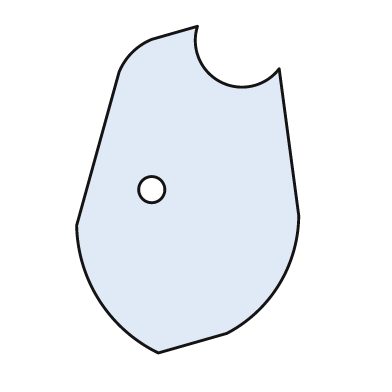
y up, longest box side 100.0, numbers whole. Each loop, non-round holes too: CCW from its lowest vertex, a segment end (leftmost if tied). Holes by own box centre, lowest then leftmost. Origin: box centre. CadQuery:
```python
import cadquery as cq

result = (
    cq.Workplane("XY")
    .moveTo(-9.0, -50.0)
    .lineTo(12.0, -44.0)
    .threePointArc((28.0, -29.0), (34.0, -8.0))
    .lineTo(28.0, 37.0)
    .threePointArc((10.0, 33.0), (3.0, 50.0))
    .lineTo(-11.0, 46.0)
    .threePointArc((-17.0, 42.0), (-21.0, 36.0))
    .lineTo(-34.0, -11.0)
    .threePointArc((-27.0, -34.0), (-9.0, -50.0))
    .close()
    .moveTo(-11.0, 0.0)
    .circle(4.0)
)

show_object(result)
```